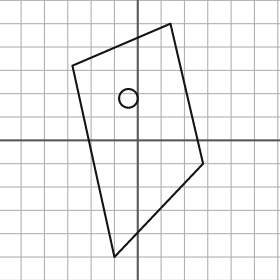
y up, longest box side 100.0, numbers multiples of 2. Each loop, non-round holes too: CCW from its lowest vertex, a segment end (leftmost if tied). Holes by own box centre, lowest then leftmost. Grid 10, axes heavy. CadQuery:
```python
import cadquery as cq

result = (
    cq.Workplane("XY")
    .moveTo(-10.0, -50.0)
    .lineTo(28.0, -10.0)
    .lineTo(14.0, 50.0)
    .lineTo(-28.0, 32.0)
    .close()
    .moveTo(-4.0, 18.0)
    .circle(4.0)
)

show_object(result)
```